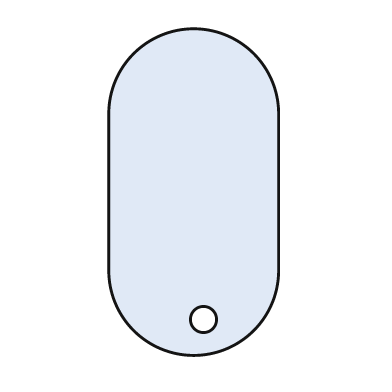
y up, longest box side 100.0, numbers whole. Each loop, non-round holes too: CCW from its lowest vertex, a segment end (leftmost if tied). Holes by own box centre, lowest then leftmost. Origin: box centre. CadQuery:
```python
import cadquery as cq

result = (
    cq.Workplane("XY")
    .moveTo(-26.0, -24.0)
    .threePointArc((0.0, -50.0), (26.0, -24.0))
    .lineTo(26.0, 24.0)
    .threePointArc((0.0, 50.0), (-26.0, 24.0))
    .close()
    .moveTo(3.0, -39.0)
    .circle(4.0)
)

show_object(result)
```